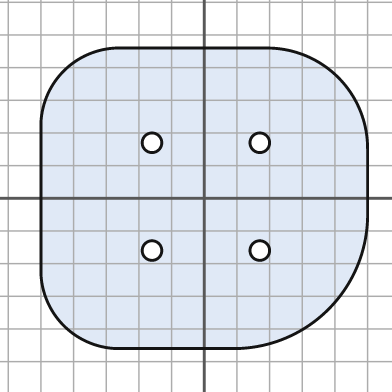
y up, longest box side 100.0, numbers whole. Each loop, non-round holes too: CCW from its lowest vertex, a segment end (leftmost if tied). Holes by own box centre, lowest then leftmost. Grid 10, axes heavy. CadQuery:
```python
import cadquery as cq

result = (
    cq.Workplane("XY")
    .moveTo(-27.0, -46.0)
    .lineTo(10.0, -46.0)
    .threePointArc((38.0, -34.0), (50.0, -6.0))
    .lineTo(50.0, 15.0)
    .threePointArc((41.0, 37.0), (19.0, 46.0))
    .lineTo(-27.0, 46.0)
    .threePointArc((-43.0, 39.0), (-50.0, 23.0))
    .lineTo(-50.0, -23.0)
    .threePointArc((-43.0, -39.0), (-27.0, -46.0))
    .close()
    .moveTo(-16.0, -16.0)
    .circle(3.0)
    .moveTo(17.0, -16.0)
    .circle(3.0)
    .moveTo(-16.0, 17.0)
    .circle(3.0)
    .moveTo(17.0, 17.0)
    .circle(3.0)
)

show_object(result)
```